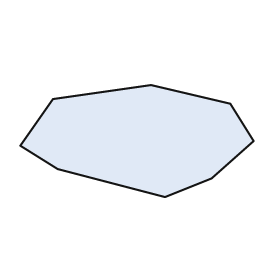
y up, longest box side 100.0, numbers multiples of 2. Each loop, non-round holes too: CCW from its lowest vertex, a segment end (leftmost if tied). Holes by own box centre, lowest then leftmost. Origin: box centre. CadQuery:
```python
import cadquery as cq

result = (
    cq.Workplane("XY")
    .moveTo(12.0, -24.0)
    .lineTo(32.0, -16.0)
    .lineTo(50.0, 0.0)
    .lineTo(40.0, 16.0)
    .lineTo(6.0, 24.0)
    .lineTo(-36.0, 18.0)
    .lineTo(-50.0, -2.0)
    .lineTo(-34.0, -12.0)
    .close()
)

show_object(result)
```